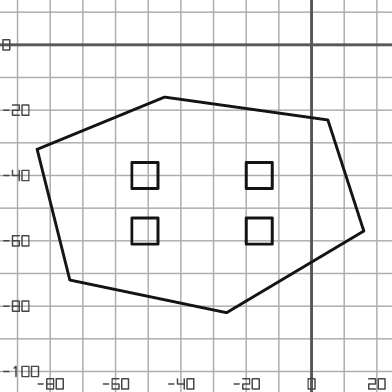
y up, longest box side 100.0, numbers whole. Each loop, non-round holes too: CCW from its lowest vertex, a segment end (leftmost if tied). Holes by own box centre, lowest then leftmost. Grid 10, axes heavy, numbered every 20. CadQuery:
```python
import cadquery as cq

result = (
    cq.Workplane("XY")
    .moveTo(-26.0, -82.0)
    .lineTo(16.0, -57.0)
    .lineTo(5.0, -23.0)
    .lineTo(-45.0, -16.0)
    .lineTo(-84.0, -32.0)
    .lineTo(-74.0, -72.0)
    .close()
    .moveTo(-55.0, -61.0)
    .lineTo(-47.0, -61.0)
    .lineTo(-47.0, -53.0)
    .lineTo(-55.0, -53.0)
    .close()
    .moveTo(-20.0, -61.0)
    .lineTo(-12.0, -61.0)
    .lineTo(-12.0, -53.0)
    .lineTo(-20.0, -53.0)
    .close()
    .moveTo(-55.0, -44.0)
    .lineTo(-47.0, -44.0)
    .lineTo(-47.0, -36.0)
    .lineTo(-55.0, -36.0)
    .close()
    .moveTo(-20.0, -44.0)
    .lineTo(-12.0, -44.0)
    .lineTo(-12.0, -36.0)
    .lineTo(-20.0, -36.0)
    .close()
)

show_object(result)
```